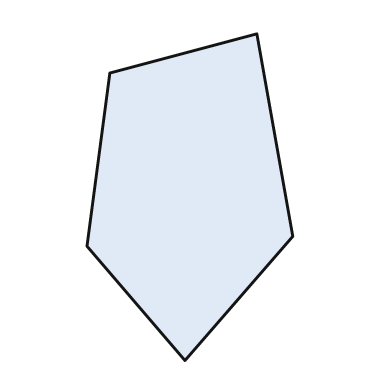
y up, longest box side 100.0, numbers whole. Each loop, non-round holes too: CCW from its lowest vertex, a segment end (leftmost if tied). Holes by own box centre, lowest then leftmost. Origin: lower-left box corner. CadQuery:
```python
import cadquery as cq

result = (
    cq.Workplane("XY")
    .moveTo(30.0, 0.0)
    .lineTo(63.0, 38.0)
    .lineTo(52.0, 100.0)
    .lineTo(7.0, 88.0)
    .lineTo(0.0, 35.0)
    .close()
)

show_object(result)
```